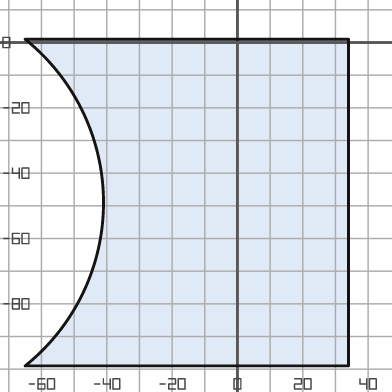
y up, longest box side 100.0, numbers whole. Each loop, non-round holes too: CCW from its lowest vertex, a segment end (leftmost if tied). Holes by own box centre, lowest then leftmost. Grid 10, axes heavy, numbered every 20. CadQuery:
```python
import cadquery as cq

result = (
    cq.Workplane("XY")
    .moveTo(-65.0, -99.0)
    .lineTo(34.0, -99.0)
    .lineTo(34.0, 1.0)
    .lineTo(-65.0, 1.0)
    .threePointArc((-41.0, -49.0), (-65.0, -99.0))
    .close()
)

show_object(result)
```